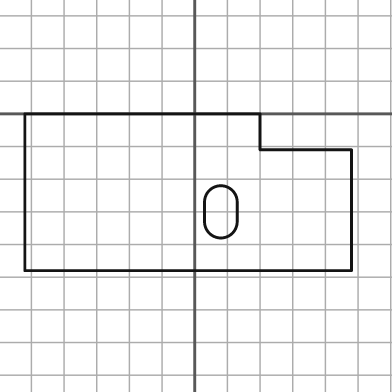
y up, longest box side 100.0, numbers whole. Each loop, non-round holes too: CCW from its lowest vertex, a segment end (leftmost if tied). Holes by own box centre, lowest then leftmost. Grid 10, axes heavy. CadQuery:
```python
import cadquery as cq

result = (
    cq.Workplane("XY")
    .moveTo(-52.0, -48.0)
    .lineTo(48.0, -48.0)
    .lineTo(48.0, -11.0)
    .lineTo(20.0, -11.0)
    .lineTo(20.0, 0.0)
    .lineTo(-52.0, 0.0)
    .close()
    .moveTo(3.0, -33.0)
    .threePointArc((8.0, -38.0), (13.0, -33.0))
    .lineTo(13.0, -27.0)
    .threePointArc((8.0, -22.0), (3.0, -27.0))
    .close()
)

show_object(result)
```